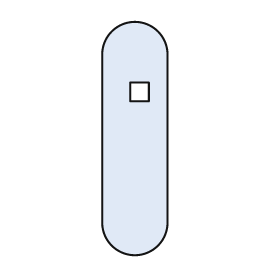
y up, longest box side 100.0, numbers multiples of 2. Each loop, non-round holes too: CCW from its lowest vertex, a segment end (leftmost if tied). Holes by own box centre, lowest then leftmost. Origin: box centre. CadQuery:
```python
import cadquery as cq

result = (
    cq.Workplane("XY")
    .moveTo(-14.0, -36.0)
    .threePointArc((0.0, -50.0), (14.0, -36.0))
    .lineTo(14.0, 36.0)
    .threePointArc((0.0, 50.0), (-14.0, 36.0))
    .close()
    .moveTo(-2.0, 16.0)
    .lineTo(6.0, 16.0)
    .lineTo(6.0, 24.0)
    .lineTo(-2.0, 24.0)
    .close()
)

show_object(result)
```